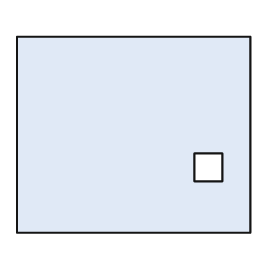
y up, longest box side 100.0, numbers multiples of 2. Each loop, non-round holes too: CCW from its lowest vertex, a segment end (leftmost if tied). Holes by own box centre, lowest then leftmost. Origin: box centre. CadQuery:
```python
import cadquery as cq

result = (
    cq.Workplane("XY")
    .moveTo(-50.0, -42.0)
    .lineTo(50.0, -42.0)
    .lineTo(50.0, 42.0)
    .lineTo(-50.0, 42.0)
    .close()
    .moveTo(26.0, -20.0)
    .lineTo(38.0, -20.0)
    .lineTo(38.0, -8.0)
    .lineTo(26.0, -8.0)
    .close()
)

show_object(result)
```